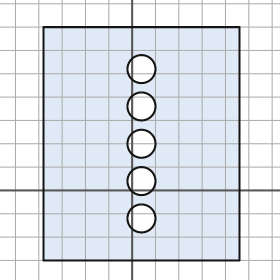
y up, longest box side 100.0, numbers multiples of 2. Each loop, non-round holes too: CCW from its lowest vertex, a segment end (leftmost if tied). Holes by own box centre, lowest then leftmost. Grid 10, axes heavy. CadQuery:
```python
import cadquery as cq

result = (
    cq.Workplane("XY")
    .moveTo(-38.0, -30.0)
    .lineTo(46.0, -30.0)
    .lineTo(46.0, 70.0)
    .lineTo(-38.0, 70.0)
    .close()
    .moveTo(4.0, -12.0)
    .circle(6.0)
    .moveTo(4.0, 4.0)
    .circle(6.0)
    .moveTo(4.0, 20.0)
    .circle(6.0)
    .moveTo(4.0, 36.0)
    .circle(6.0)
    .moveTo(4.0, 52.0)
    .circle(6.0)
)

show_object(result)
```